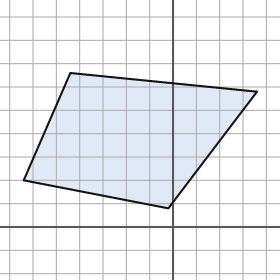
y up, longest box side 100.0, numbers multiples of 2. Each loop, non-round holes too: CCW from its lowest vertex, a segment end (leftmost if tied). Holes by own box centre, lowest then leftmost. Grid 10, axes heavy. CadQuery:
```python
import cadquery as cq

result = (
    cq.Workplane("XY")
    .moveTo(-2.0, 8.0)
    .lineTo(36.0, 58.0)
    .lineTo(-44.0, 66.0)
    .lineTo(-64.0, 20.0)
    .close()
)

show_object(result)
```